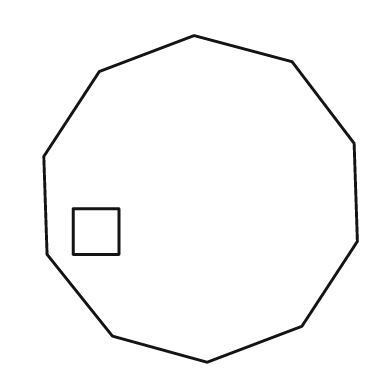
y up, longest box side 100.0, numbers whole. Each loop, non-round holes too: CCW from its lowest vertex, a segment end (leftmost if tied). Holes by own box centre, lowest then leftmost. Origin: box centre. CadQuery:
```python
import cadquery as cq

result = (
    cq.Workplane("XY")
    .moveTo(2.0, -50.0)
    .lineTo(31.0, -39.0)
    .lineTo(48.0, -13.0)
    .lineTo(47.0, 17.0)
    .lineTo(28.0, 42.0)
    .lineTo(-2.0, 50.0)
    .lineTo(-31.0, 39.0)
    .lineTo(-48.0, 13.0)
    .lineTo(-47.0, -17.0)
    .lineTo(-27.0, -42.0)
    .close()
    .moveTo(-39.0, -17.0)
    .lineTo(-25.0, -17.0)
    .lineTo(-25.0, -3.0)
    .lineTo(-39.0, -3.0)
    .close()
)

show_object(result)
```